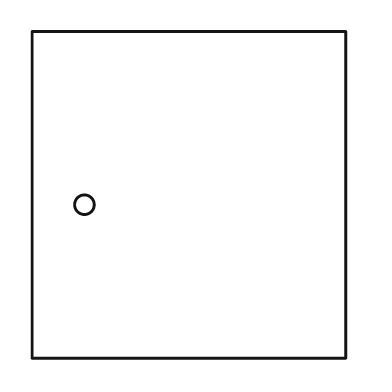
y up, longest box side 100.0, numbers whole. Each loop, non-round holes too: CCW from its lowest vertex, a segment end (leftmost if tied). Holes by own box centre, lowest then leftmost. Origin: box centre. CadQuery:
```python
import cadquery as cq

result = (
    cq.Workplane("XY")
    .moveTo(-48.0, -50.0)
    .lineTo(48.0, -50.0)
    .lineTo(48.0, 50.0)
    .lineTo(-48.0, 50.0)
    .close()
    .moveTo(-32.0, -3.0)
    .circle(3.0)
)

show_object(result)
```